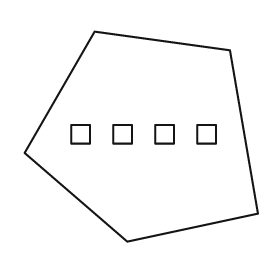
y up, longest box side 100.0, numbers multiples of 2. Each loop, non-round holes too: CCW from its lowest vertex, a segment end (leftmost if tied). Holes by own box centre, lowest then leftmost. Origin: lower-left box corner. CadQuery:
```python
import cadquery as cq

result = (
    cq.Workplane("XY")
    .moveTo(44.0, 0.0)
    .lineTo(100.0, 12.0)
    .lineTo(88.0, 82.0)
    .lineTo(30.0, 90.0)
    .lineTo(0.0, 38.0)
    .close()
    .moveTo(20.0, 42.0)
    .lineTo(28.0, 42.0)
    .lineTo(28.0, 50.0)
    .lineTo(20.0, 50.0)
    .close()
    .moveTo(38.0, 42.0)
    .lineTo(46.0, 42.0)
    .lineTo(46.0, 50.0)
    .lineTo(38.0, 50.0)
    .close()
    .moveTo(56.0, 42.0)
    .lineTo(64.0, 42.0)
    .lineTo(64.0, 50.0)
    .lineTo(56.0, 50.0)
    .close()
    .moveTo(74.0, 42.0)
    .lineTo(82.0, 42.0)
    .lineTo(82.0, 50.0)
    .lineTo(74.0, 50.0)
    .close()
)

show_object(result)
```